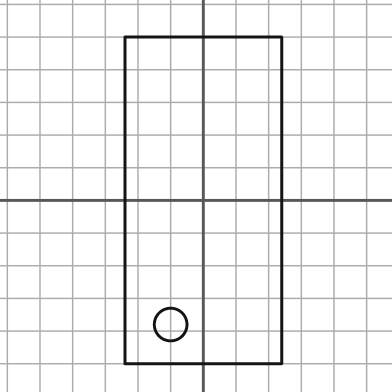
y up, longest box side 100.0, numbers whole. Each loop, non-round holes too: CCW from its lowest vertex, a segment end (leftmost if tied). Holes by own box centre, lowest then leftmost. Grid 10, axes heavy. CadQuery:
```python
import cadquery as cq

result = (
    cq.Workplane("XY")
    .moveTo(-24.0, -50.0)
    .lineTo(24.0, -50.0)
    .lineTo(24.0, 50.0)
    .lineTo(-24.0, 50.0)
    .close()
    .moveTo(-10.0, -38.0)
    .circle(5.0)
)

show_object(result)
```